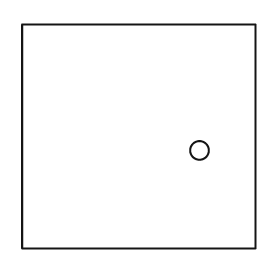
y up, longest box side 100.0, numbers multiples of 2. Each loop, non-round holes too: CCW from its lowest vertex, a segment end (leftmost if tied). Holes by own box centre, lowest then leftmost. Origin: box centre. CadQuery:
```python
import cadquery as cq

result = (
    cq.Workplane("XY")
    .moveTo(-50.0, -48.0)
    .lineTo(50.0, -48.0)
    .lineTo(50.0, 48.0)
    .lineTo(-50.0, 48.0)
    .close()
    .moveTo(26.0, -6.0)
    .circle(4.0)
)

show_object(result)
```